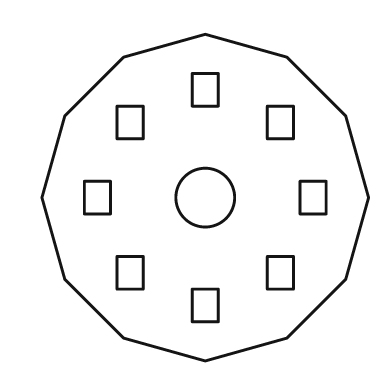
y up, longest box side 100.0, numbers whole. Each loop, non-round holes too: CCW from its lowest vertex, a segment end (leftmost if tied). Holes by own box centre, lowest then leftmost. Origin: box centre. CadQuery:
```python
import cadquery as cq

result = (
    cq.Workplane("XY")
    .moveTo(0.0, -50.0)
    .lineTo(25.0, -43.0)
    .lineTo(43.0, -25.0)
    .lineTo(50.0, 0.0)
    .lineTo(43.0, 25.0)
    .lineTo(25.0, 43.0)
    .lineTo(0.0, 50.0)
    .lineTo(-25.0, 43.0)
    .lineTo(-43.0, 25.0)
    .lineTo(-50.0, 0.0)
    .lineTo(-43.0, -25.0)
    .lineTo(-25.0, -43.0)
    .close()
    .moveTo(-4.0, -38.0)
    .lineTo(4.0, -38.0)
    .lineTo(4.0, -28.0)
    .lineTo(-4.0, -28.0)
    .close()
    .moveTo(-27.0, -28.0)
    .lineTo(-19.0, -28.0)
    .lineTo(-19.0, -18.0)
    .lineTo(-27.0, -18.0)
    .close()
    .moveTo(19.0, -28.0)
    .lineTo(27.0, -28.0)
    .lineTo(27.0, -18.0)
    .lineTo(19.0, -18.0)
    .close()
    .moveTo(-37.0, -5.0)
    .lineTo(-29.0, -5.0)
    .lineTo(-29.0, 5.0)
    .lineTo(-37.0, 5.0)
    .close()
    .moveTo(0.0, 0.0)
    .circle(9.0)
    .moveTo(29.0, -5.0)
    .lineTo(37.0, -5.0)
    .lineTo(37.0, 5.0)
    .lineTo(29.0, 5.0)
    .close()
    .moveTo(-27.0, 18.0)
    .lineTo(-19.0, 18.0)
    .lineTo(-19.0, 28.0)
    .lineTo(-27.0, 28.0)
    .close()
    .moveTo(19.0, 18.0)
    .lineTo(27.0, 18.0)
    .lineTo(27.0, 28.0)
    .lineTo(19.0, 28.0)
    .close()
    .moveTo(-4.0, 28.0)
    .lineTo(4.0, 28.0)
    .lineTo(4.0, 38.0)
    .lineTo(-4.0, 38.0)
    .close()
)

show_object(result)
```